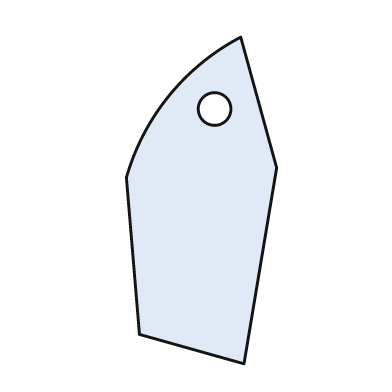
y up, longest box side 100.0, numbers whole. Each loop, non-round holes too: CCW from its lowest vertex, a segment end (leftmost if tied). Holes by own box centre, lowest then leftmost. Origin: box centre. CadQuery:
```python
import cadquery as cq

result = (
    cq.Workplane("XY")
    .moveTo(13.0, -50.0)
    .lineTo(23.0, 10.0)
    .lineTo(12.0, 50.0)
    .threePointArc((-10.0, 32.0), (-23.0, 7.0))
    .lineTo(-19.0, -41.0)
    .close()
    .moveTo(4.0, 28.0)
    .circle(5.0)
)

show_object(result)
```